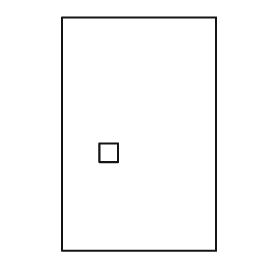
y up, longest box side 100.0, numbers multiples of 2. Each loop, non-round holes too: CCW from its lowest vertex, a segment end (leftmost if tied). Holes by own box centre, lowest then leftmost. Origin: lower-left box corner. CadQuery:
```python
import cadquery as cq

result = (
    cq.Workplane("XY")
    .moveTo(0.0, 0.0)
    .lineTo(66.0, 0.0)
    .lineTo(66.0, 100.0)
    .lineTo(0.0, 100.0)
    .close()
    .moveTo(16.0, 38.0)
    .lineTo(24.0, 38.0)
    .lineTo(24.0, 46.0)
    .lineTo(16.0, 46.0)
    .close()
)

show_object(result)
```